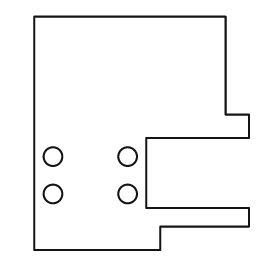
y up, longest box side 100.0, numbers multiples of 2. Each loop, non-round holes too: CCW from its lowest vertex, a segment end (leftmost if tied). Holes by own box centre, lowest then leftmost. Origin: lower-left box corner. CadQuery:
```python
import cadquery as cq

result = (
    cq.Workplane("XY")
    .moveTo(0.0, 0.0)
    .lineTo(54.0, 0.0)
    .lineTo(54.0, 10.0)
    .lineTo(92.0, 10.0)
    .lineTo(92.0, 18.0)
    .lineTo(48.0, 18.0)
    .lineTo(48.0, 48.0)
    .lineTo(92.0, 48.0)
    .lineTo(92.0, 58.0)
    .lineTo(82.0, 58.0)
    .lineTo(82.0, 100.0)
    .lineTo(0.0, 100.0)
    .close()
    .moveTo(8.0, 24.0)
    .circle(4.0)
    .moveTo(40.0, 24.0)
    .circle(4.0)
    .moveTo(8.0, 40.0)
    .circle(4.0)
    .moveTo(40.0, 40.0)
    .circle(4.0)
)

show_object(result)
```